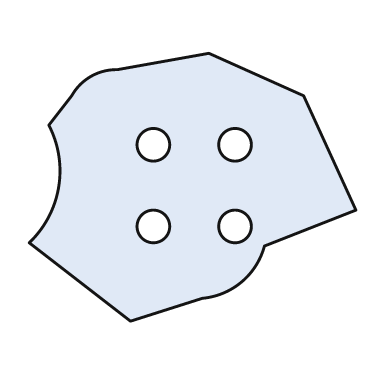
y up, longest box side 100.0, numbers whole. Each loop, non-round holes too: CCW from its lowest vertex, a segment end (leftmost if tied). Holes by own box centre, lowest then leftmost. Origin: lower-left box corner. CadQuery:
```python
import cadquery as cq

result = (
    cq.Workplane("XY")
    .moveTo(31.0, 0.0)
    .lineTo(53.0, 7.0)
    .threePointArc((65.0, 12.0), (72.0, 23.0))
    .lineTo(100.0, 34.0)
    .lineTo(84.0, 69.0)
    .lineTo(55.0, 82.0)
    .lineTo(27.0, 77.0)
    .threePointArc((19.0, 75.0), (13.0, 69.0))
    .lineTo(6.0, 60.0)
    .threePointArc((9.0, 41.0), (0.0, 24.0))
    .close()
    .moveTo(38.0, 29.0)
    .circle(5.0)
    .moveTo(63.0, 29.0)
    .circle(5.0)
    .moveTo(38.0, 54.0)
    .circle(5.0)
    .moveTo(63.0, 54.0)
    .circle(5.0)
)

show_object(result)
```